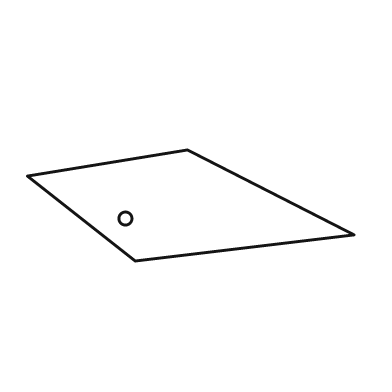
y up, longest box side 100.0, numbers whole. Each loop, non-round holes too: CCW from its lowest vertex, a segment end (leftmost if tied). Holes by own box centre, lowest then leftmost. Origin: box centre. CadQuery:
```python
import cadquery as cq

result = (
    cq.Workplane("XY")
    .moveTo(-17.0, -17.0)
    .lineTo(50.0, -9.0)
    .lineTo(-1.0, 17.0)
    .lineTo(-50.0, 9.0)
    .close()
    .moveTo(-20.0, -4.0)
    .circle(2.0)
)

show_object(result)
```